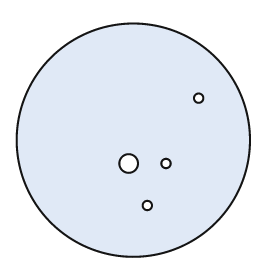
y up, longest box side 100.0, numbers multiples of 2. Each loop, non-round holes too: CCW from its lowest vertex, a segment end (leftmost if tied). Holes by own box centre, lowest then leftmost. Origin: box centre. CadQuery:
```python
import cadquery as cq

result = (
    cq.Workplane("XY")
    .moveTo(0.0, 0.0)
    .circle(50.0)
    .moveTo(6.0, -28.0)
    .circle(2.0)
    .moveTo(-2.0, -10.0)
    .circle(4.0)
    .moveTo(14.0, -10.0)
    .circle(2.0)
    .moveTo(28.0, 18.0)
    .circle(2.0)
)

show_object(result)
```